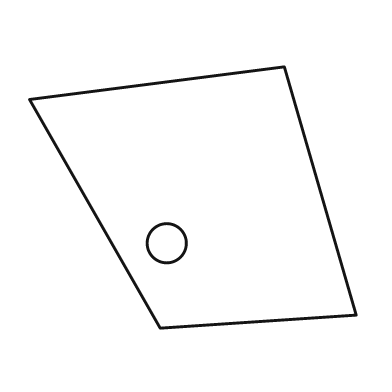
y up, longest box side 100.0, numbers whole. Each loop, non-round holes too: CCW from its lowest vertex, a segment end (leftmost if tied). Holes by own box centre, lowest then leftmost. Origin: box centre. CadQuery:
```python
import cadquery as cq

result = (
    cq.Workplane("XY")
    .moveTo(-10.0, -40.0)
    .lineTo(50.0, -36.0)
    .lineTo(28.0, 40.0)
    .lineTo(-50.0, 30.0)
    .close()
    .moveTo(-8.0, -14.0)
    .circle(6.0)
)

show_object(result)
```